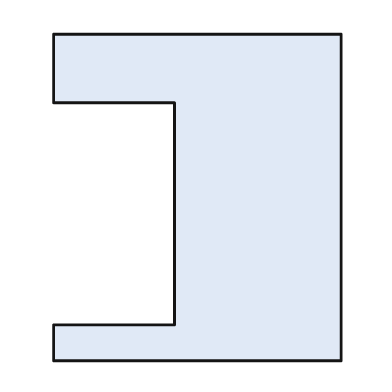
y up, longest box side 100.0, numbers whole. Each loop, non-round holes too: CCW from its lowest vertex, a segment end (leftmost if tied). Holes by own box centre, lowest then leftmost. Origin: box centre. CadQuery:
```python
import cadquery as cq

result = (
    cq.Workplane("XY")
    .moveTo(-44.0, -50.0)
    .lineTo(44.0, -50.0)
    .lineTo(44.0, 50.0)
    .lineTo(-44.0, 50.0)
    .lineTo(-44.0, 29.0)
    .lineTo(-7.0, 29.0)
    .lineTo(-7.0, -39.0)
    .lineTo(-44.0, -39.0)
    .close()
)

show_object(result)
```